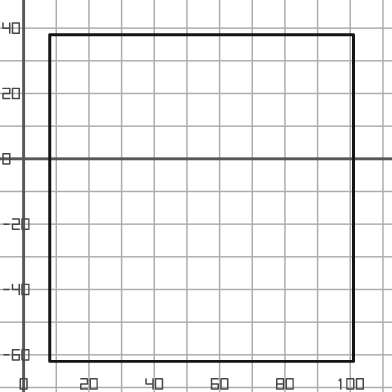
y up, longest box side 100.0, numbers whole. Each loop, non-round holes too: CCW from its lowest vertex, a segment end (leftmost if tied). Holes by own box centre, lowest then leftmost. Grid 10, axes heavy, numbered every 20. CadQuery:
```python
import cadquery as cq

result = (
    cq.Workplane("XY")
    .moveTo(8.0, -62.0)
    .lineTo(101.0, -62.0)
    .lineTo(101.0, 38.0)
    .lineTo(8.0, 38.0)
    .close()
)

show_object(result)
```